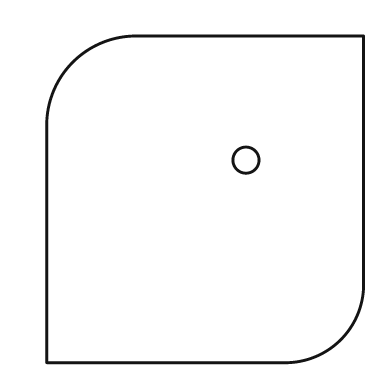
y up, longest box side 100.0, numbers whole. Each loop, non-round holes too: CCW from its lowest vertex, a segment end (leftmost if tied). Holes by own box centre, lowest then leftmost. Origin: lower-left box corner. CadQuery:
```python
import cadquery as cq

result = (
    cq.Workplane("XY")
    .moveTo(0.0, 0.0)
    .lineTo(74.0, 0.0)
    .threePointArc((90.0, 7.0), (97.0, 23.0))
    .lineTo(97.0, 100.0)
    .lineTo(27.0, 100.0)
    .threePointArc((8.0, 92.0), (0.0, 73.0))
    .close()
    .moveTo(61.0, 62.0)
    .circle(4.0)
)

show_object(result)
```